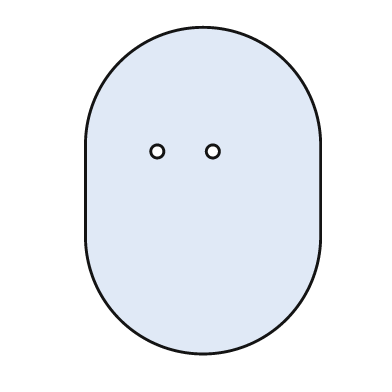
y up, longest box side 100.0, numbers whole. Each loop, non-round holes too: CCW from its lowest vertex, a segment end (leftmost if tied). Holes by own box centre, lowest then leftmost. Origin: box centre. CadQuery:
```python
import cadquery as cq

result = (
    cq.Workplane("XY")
    .moveTo(-36.0, -14.0)
    .threePointArc((0.0, -50.0), (36.0, -14.0))
    .lineTo(36.0, 14.0)
    .threePointArc((0.0, 50.0), (-36.0, 14.0))
    .close()
    .moveTo(-14.0, 12.0)
    .circle(2.0)
    .moveTo(3.0, 12.0)
    .circle(2.0)
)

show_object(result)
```